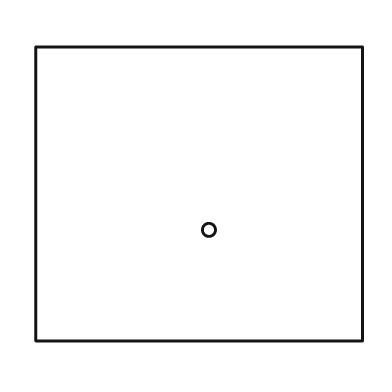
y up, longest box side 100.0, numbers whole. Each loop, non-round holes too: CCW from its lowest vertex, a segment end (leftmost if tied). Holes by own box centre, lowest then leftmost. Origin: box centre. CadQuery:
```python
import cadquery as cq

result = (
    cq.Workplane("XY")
    .moveTo(-50.0, -45.0)
    .lineTo(50.0, -45.0)
    .lineTo(50.0, 45.0)
    .lineTo(-50.0, 45.0)
    .close()
    .moveTo(3.0, -11.0)
    .circle(2.0)
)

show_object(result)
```